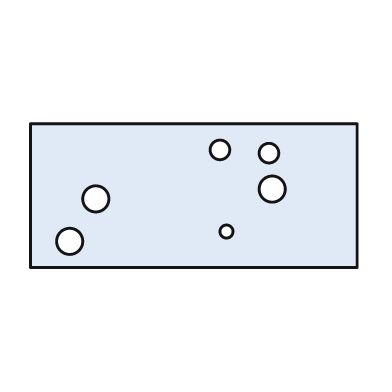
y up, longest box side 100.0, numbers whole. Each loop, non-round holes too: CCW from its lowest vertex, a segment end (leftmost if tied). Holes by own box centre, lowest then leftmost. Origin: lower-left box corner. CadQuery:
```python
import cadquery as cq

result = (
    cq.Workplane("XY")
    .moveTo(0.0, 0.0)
    .lineTo(100.0, 0.0)
    .lineTo(100.0, 44.0)
    .lineTo(0.0, 44.0)
    .close()
    .moveTo(12.0, 8.0)
    .circle(4.0)
    .moveTo(60.0, 11.0)
    .circle(2.0)
    .moveTo(20.0, 21.0)
    .circle(4.0)
    .moveTo(74.0, 24.0)
    .circle(4.0)
    .moveTo(73.0, 35.0)
    .circle(3.0)
    .moveTo(58.0, 36.0)
    .circle(3.0)
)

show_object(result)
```